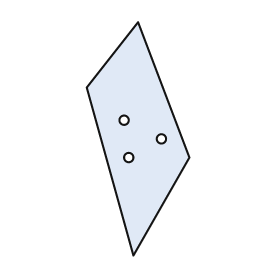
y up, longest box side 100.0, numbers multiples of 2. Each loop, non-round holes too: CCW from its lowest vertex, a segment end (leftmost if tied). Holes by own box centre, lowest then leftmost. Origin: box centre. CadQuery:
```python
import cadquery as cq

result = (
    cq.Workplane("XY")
    .moveTo(-2.0, -50.0)
    .lineTo(22.0, -8.0)
    .lineTo(0.0, 50.0)
    .lineTo(-22.0, 22.0)
    .close()
    .moveTo(-4.0, -8.0)
    .circle(2.0)
    .moveTo(10.0, 0.0)
    .circle(2.0)
    .moveTo(-6.0, 8.0)
    .circle(2.0)
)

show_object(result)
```